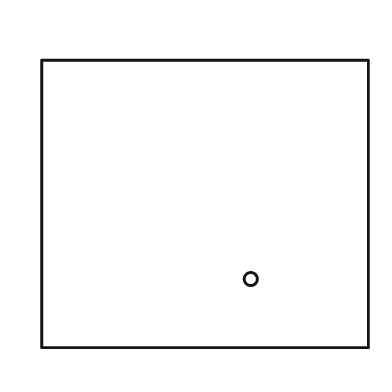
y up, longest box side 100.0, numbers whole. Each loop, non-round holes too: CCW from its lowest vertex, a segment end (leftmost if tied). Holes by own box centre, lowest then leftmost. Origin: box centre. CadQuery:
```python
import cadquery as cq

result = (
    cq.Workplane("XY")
    .moveTo(-50.0, -44.0)
    .lineTo(50.0, -44.0)
    .lineTo(50.0, 44.0)
    .lineTo(-50.0, 44.0)
    .close()
    .moveTo(14.0, -23.0)
    .circle(2.0)
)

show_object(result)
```